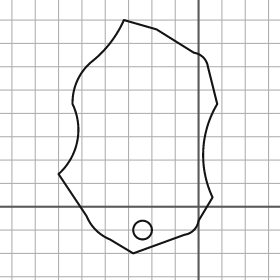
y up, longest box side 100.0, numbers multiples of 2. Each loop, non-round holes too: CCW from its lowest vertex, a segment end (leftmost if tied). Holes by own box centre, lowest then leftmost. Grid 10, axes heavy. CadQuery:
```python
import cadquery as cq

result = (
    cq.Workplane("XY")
    .moveTo(-28.0, -20.0)
    .lineTo(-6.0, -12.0)
    .threePointArc((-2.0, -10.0), (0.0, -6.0))
    .lineTo(6.0, 4.0)
    .threePointArc((2.0, 24.0), (8.0, 44.0))
    .lineTo(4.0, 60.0)
    .threePointArc((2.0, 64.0), (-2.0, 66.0))
    .lineTo(-18.0, 76.0)
    .lineTo(-32.0, 80.0)
    .threePointArc((-38.0, 70.0), (-46.0, 62.0))
    .threePointArc((-52.0, 54.0), (-54.0, 44.0))
    .threePointArc((-52.0, 28.0), (-60.0, 14.0))
    .lineTo(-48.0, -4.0)
    .threePointArc((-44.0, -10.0), (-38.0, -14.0))
    .close()
    .moveTo(-24.0, -10.0)
    .circle(4.0)
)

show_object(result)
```